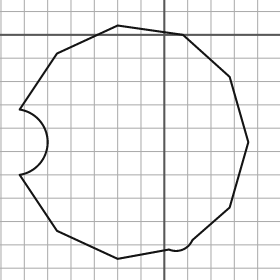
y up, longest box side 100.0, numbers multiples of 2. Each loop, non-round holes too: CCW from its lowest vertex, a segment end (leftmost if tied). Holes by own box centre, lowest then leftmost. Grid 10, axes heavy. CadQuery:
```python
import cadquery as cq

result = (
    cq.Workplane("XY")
    .moveTo(-20.0, -96.0)
    .lineTo(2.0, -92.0)
    .threePointArc((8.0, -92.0), (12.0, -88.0))
    .lineTo(28.0, -74.0)
    .lineTo(36.0, -46.0)
    .lineTo(28.0, -18.0)
    .lineTo(8.0, 0.0)
    .lineTo(-20.0, 4.0)
    .lineTo(-46.0, -8.0)
    .lineTo(-62.0, -32.0)
    .threePointArc((-50.0, -46.0), (-62.0, -60.0))
    .lineTo(-46.0, -84.0)
    .close()
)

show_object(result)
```